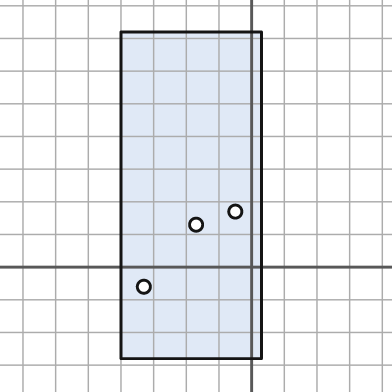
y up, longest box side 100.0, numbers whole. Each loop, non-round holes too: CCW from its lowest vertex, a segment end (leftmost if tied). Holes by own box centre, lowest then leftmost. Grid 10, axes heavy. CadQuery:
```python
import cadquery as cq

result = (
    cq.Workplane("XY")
    .moveTo(-40.0, -28.0)
    .lineTo(3.0, -28.0)
    .lineTo(3.0, 72.0)
    .lineTo(-40.0, 72.0)
    .close()
    .moveTo(-33.0, -6.0)
    .circle(2.0)
    .moveTo(-17.0, 13.0)
    .circle(2.0)
    .moveTo(-5.0, 17.0)
    .circle(2.0)
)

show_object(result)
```